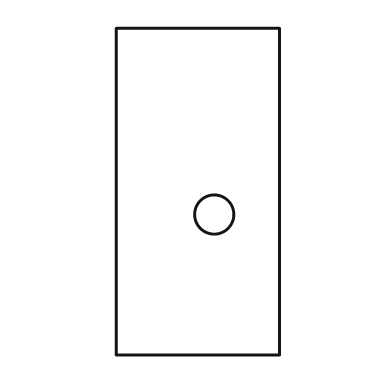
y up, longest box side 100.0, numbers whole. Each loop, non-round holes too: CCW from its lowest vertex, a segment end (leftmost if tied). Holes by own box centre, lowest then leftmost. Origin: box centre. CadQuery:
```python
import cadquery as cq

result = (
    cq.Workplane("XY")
    .moveTo(-25.0, -50.0)
    .lineTo(25.0, -50.0)
    .lineTo(25.0, 50.0)
    .lineTo(-25.0, 50.0)
    .close()
    .moveTo(5.0, -7.0)
    .circle(6.0)
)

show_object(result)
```